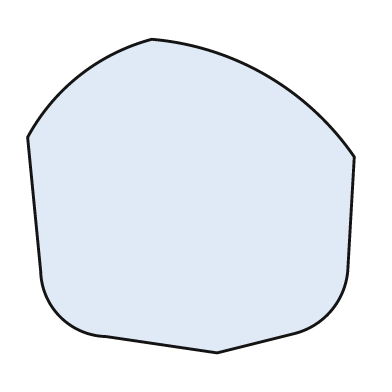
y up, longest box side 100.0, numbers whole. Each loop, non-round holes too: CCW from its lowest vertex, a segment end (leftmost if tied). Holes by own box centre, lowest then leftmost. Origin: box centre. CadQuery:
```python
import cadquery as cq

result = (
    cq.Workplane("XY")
    .moveTo(8.0, -48.0)
    .lineTo(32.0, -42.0)
    .threePointArc((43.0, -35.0), (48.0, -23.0))
    .lineTo(50.0, 12.0)
    .threePointArc((23.0, 37.0), (-12.0, 48.0))
    .threePointArc((-34.0, 37.0), (-50.0, 18.0))
    .lineTo(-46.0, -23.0)
    .threePointArc((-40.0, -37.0), (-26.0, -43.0))
    .close()
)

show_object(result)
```